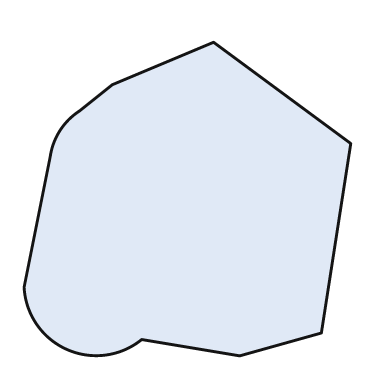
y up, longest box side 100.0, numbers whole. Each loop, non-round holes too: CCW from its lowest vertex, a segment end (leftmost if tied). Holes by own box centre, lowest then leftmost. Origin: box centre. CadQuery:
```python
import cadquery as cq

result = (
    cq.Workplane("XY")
    .moveTo(16.0, -48.0)
    .lineTo(41.0, -41.0)
    .lineTo(50.0, 17.0)
    .lineTo(8.0, 48.0)
    .lineTo(-23.0, 35.0)
    .lineTo(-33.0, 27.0)
    .threePointArc((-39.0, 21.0), (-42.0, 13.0))
    .lineTo(-50.0, -27.0)
    .threePointArc((-37.0, -46.0), (-14.0, -43.0))
    .close()
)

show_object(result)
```